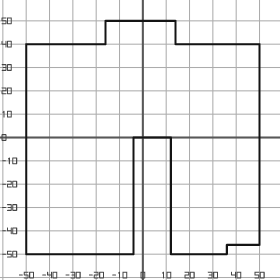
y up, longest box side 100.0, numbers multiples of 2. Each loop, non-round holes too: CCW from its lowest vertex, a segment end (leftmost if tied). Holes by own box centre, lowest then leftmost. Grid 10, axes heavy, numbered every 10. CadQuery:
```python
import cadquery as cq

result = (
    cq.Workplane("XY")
    .moveTo(-50.0, -50.0)
    .lineTo(-4.0, -50.0)
    .lineTo(-4.0, 0.0)
    .lineTo(12.0, 0.0)
    .lineTo(12.0, -50.0)
    .lineTo(36.0, -50.0)
    .lineTo(36.0, -46.0)
    .lineTo(50.0, -46.0)
    .lineTo(50.0, 40.0)
    .lineTo(14.0, 40.0)
    .lineTo(14.0, 50.0)
    .lineTo(-16.0, 50.0)
    .lineTo(-16.0, 40.0)
    .lineTo(-50.0, 40.0)
    .close()
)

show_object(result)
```